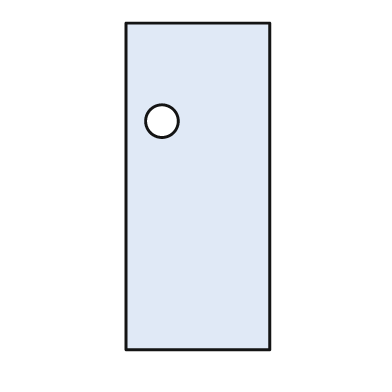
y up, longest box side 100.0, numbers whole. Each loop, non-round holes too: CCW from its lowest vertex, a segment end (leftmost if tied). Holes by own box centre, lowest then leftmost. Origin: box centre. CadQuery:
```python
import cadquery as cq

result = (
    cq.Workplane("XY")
    .moveTo(-22.0, -50.0)
    .lineTo(22.0, -50.0)
    .lineTo(22.0, 50.0)
    .lineTo(-22.0, 50.0)
    .close()
    .moveTo(-11.0, 20.0)
    .circle(5.0)
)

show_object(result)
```